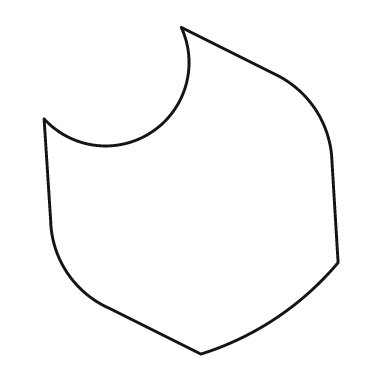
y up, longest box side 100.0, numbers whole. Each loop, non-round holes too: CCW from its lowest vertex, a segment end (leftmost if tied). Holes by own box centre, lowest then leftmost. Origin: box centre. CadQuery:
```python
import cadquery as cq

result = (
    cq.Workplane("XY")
    .moveTo(3.0, -50.0)
    .threePointArc((26.0, -39.0), (45.0, -22.0))
    .lineTo(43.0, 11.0)
    .threePointArc((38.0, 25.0), (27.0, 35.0))
    .lineTo(-3.0, 50.0)
    .threePointArc((-12.0, 18.0), (-45.0, 22.0))
    .lineTo(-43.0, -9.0)
    .threePointArc((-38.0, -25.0), (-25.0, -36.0))
    .close()
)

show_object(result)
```